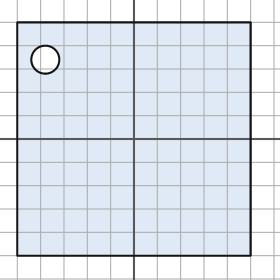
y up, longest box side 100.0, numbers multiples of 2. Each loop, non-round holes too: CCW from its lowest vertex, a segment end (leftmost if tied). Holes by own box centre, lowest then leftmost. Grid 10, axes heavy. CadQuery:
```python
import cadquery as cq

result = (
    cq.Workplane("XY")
    .moveTo(-50.0, -50.0)
    .lineTo(50.0, -50.0)
    .lineTo(50.0, 50.0)
    .lineTo(-50.0, 50.0)
    .close()
    .moveTo(-38.0, 34.0)
    .circle(6.0)
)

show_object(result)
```